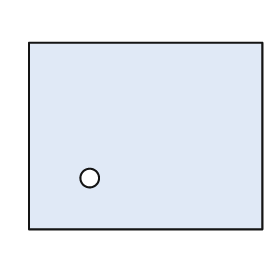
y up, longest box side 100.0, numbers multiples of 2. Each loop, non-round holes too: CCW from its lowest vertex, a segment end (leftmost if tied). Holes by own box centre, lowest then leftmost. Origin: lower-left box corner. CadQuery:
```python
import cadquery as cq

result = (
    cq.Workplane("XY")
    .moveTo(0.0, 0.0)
    .lineTo(100.0, 0.0)
    .lineTo(100.0, 80.0)
    .lineTo(0.0, 80.0)
    .close()
    .moveTo(26.0, 22.0)
    .circle(4.0)
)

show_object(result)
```